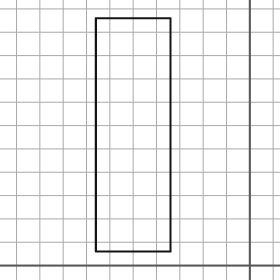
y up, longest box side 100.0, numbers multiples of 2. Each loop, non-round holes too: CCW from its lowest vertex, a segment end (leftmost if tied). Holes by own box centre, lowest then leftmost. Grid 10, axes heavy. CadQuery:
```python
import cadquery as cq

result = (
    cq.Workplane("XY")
    .moveTo(-66.0, 6.0)
    .lineTo(-34.0, 6.0)
    .lineTo(-34.0, 106.0)
    .lineTo(-66.0, 106.0)
    .close()
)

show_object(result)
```